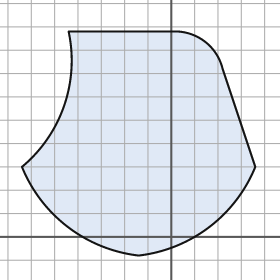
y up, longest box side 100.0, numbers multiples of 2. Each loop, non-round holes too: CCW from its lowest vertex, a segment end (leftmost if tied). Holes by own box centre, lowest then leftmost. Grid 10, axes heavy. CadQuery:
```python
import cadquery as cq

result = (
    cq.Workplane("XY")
    .moveTo(-14.0, -8.0)
    .threePointArc((16.0, 4.0), (36.0, 30.0))
    .lineTo(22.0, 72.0)
    .threePointArc((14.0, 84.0), (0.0, 88.0))
    .lineTo(-44.0, 88.0)
    .threePointArc((-46.0, 56.0), (-64.0, 30.0))
    .threePointArc((-44.0, 4.0), (-14.0, -8.0))
    .close()
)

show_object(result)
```